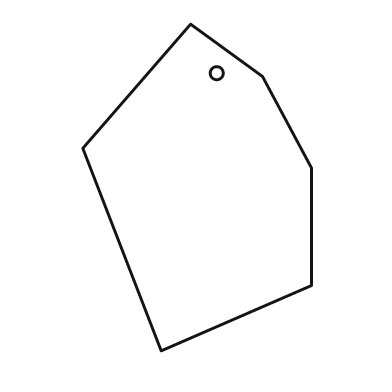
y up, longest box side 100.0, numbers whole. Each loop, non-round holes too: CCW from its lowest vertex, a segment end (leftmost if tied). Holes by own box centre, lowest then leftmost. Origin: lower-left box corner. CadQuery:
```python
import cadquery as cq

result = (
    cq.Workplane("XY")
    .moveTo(24.0, 0.0)
    .lineTo(70.0, 20.0)
    .lineTo(70.0, 56.0)
    .lineTo(55.0, 84.0)
    .lineTo(33.0, 100.0)
    .lineTo(0.0, 62.0)
    .close()
    .moveTo(41.0, 85.0)
    .circle(2.0)
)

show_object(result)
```